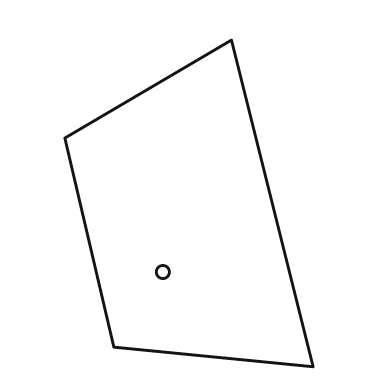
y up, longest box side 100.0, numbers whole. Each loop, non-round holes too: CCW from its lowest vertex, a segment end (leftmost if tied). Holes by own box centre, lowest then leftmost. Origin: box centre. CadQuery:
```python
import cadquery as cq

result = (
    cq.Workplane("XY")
    .moveTo(38.0, -50.0)
    .lineTo(13.0, 50.0)
    .lineTo(-38.0, 20.0)
    .lineTo(-23.0, -44.0)
    .close()
    .moveTo(-8.0, -21.0)
    .circle(2.0)
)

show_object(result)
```